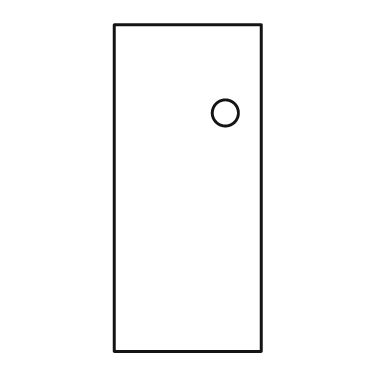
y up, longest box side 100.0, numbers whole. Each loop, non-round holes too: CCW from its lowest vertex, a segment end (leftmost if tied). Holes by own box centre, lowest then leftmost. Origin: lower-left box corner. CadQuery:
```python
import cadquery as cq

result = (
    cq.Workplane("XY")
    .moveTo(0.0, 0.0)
    .lineTo(45.0, 0.0)
    .lineTo(45.0, 100.0)
    .lineTo(0.0, 100.0)
    .close()
    .moveTo(34.0, 73.0)
    .circle(4.0)
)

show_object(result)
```